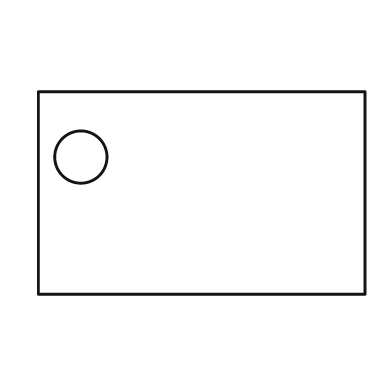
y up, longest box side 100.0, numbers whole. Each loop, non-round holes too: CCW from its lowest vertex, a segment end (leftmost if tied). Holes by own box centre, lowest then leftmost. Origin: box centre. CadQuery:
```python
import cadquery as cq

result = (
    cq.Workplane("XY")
    .moveTo(-50.0, -31.0)
    .lineTo(50.0, -31.0)
    .lineTo(50.0, 31.0)
    .lineTo(-50.0, 31.0)
    .close()
    .moveTo(-37.0, 11.0)
    .circle(8.0)
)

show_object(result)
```